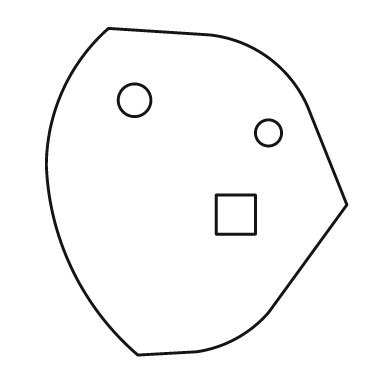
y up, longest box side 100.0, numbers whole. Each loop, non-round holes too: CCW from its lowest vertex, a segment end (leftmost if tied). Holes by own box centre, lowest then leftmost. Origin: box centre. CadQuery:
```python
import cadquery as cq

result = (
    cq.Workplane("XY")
    .moveTo(-18.0, -50.0)
    .lineTo(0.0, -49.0)
    .threePointArc((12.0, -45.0), (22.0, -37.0))
    .lineTo(46.0, -4.0)
    .lineTo(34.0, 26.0)
    .threePointArc((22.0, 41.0), (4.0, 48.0))
    .lineTo(-27.0, 50.0)
    .threePointArc((-41.0, 31.0), (-46.0, 8.0))
    .threePointArc((-38.0, -24.0), (-18.0, -50.0))
    .close()
    .moveTo(6.0, -13.0)
    .lineTo(18.0, -13.0)
    .lineTo(18.0, -1.0)
    .lineTo(6.0, -1.0)
    .close()
    .moveTo(22.0, 18.0)
    .circle(4.0)
    .moveTo(-19.0, 28.0)
    .circle(5.0)
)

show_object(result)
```